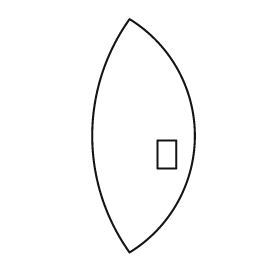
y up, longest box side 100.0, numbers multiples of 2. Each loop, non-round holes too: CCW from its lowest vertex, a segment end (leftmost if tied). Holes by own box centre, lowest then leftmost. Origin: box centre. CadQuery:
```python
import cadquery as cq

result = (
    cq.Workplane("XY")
    .moveTo(-6.0, -50.0)
    .threePointArc((22.0, 0.0), (-6.0, 50.0))
    .threePointArc((-22.0, 0.0), (-6.0, -50.0))
    .close()
    .moveTo(6.0, -14.0)
    .lineTo(14.0, -14.0)
    .lineTo(14.0, -2.0)
    .lineTo(6.0, -2.0)
    .close()
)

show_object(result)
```